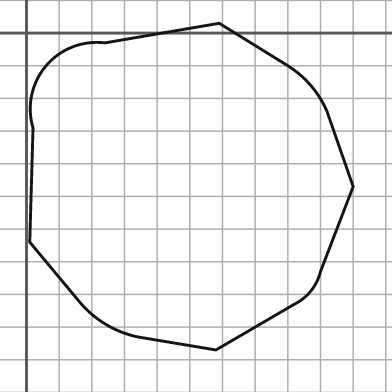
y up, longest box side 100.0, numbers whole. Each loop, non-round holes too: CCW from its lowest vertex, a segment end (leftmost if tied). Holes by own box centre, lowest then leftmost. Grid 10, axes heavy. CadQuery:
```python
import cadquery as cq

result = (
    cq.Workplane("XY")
    .moveTo(58.0, -97.0)
    .lineTo(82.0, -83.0)
    .threePointArc((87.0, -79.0), (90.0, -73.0))
    .lineTo(100.0, -47.0)
    .lineTo(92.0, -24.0)
    .threePointArc((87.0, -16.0), (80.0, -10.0))
    .lineTo(59.0, 3.0)
    .lineTo(24.0, -3.0)
    .threePointArc((6.0, -10.0), (2.0, -29.0))
    .lineTo(1.0, -64.0)
    .lineTo(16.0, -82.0)
    .threePointArc((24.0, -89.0), (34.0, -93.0))
    .close()
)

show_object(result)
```